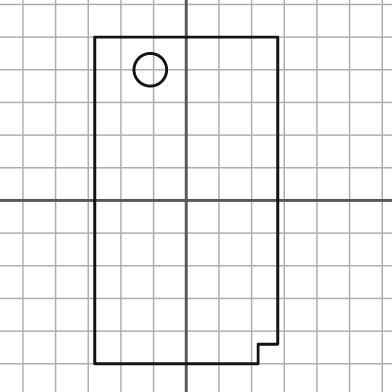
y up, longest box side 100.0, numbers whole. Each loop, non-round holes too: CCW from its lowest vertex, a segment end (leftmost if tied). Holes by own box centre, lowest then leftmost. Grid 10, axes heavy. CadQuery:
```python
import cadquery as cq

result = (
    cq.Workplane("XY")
    .moveTo(-28.0, -50.0)
    .lineTo(22.0, -50.0)
    .lineTo(22.0, -44.0)
    .lineTo(28.0, -44.0)
    .lineTo(28.0, 50.0)
    .lineTo(-28.0, 50.0)
    .close()
    .moveTo(-11.0, 40.0)
    .circle(5.0)
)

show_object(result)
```